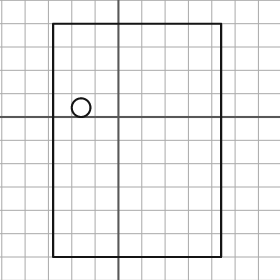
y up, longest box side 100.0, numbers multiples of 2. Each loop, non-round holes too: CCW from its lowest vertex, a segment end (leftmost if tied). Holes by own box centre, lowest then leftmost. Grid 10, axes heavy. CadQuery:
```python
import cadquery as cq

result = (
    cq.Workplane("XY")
    .moveTo(-28.0, -60.0)
    .lineTo(44.0, -60.0)
    .lineTo(44.0, 40.0)
    .lineTo(-28.0, 40.0)
    .close()
    .moveTo(-16.0, 4.0)
    .circle(4.0)
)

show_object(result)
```